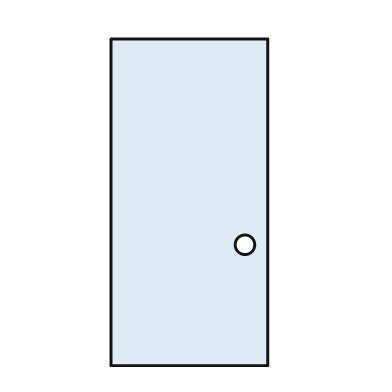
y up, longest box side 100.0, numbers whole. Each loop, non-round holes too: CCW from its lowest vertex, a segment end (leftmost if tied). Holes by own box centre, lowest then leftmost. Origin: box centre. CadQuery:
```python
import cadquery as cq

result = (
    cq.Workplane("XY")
    .moveTo(-24.0, -50.0)
    .lineTo(24.0, -50.0)
    .lineTo(24.0, 50.0)
    .lineTo(-24.0, 50.0)
    .close()
    .moveTo(17.0, -13.0)
    .circle(3.0)
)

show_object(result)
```